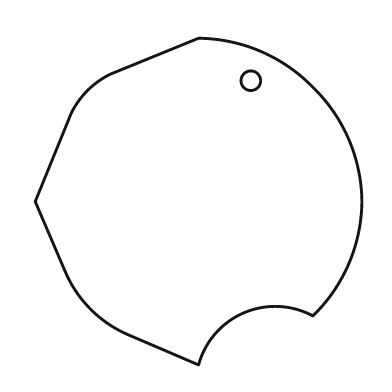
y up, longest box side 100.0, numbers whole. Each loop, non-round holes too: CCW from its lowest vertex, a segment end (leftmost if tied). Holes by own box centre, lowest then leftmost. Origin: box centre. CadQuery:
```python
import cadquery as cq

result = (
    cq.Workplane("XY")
    .moveTo(0.0, -50.0)
    .threePointArc((14.0, -34.0), (35.0, -35.0))
    .threePointArc((46.0, -19.0), (50.0, 0.0))
    .threePointArc((46.0, 19.0), (35.0, 35.0))
    .threePointArc((19.0, 46.0), (0.0, 50.0))
    .lineTo(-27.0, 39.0)
    .threePointArc((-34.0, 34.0), (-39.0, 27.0))
    .lineTo(-50.0, 0.0)
    .lineTo(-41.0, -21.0)
    .threePointArc((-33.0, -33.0), (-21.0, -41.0))
    .close()
    .moveTo(16.0, 37.0)
    .circle(3.0)
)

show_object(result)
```